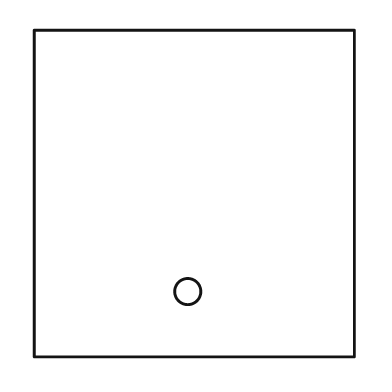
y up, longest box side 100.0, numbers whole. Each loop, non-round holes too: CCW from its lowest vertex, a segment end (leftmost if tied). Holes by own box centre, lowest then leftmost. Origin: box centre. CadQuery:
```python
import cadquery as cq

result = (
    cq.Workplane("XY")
    .moveTo(-49.0, -50.0)
    .lineTo(49.0, -50.0)
    .lineTo(49.0, 50.0)
    .lineTo(-49.0, 50.0)
    .close()
    .moveTo(-2.0, -30.0)
    .circle(4.0)
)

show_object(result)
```